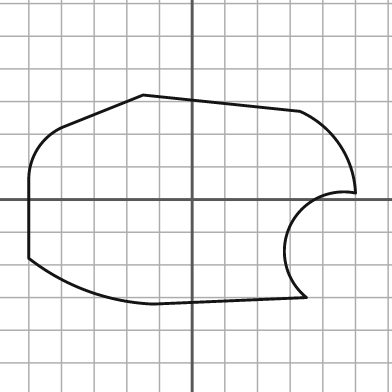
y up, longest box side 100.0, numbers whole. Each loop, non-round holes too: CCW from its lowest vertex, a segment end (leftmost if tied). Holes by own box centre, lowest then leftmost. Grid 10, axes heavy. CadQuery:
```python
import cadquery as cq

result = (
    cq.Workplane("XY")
    .moveTo(-12.0, -32.0)
    .lineTo(35.0, -30.0)
    .threePointArc((30.0, -8.0), (50.0, 2.0))
    .threePointArc((45.0, 17.0), (33.0, 27.0))
    .lineTo(-15.0, 32.0)
    .lineTo(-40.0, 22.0)
    .threePointArc((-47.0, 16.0), (-50.0, 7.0))
    .lineTo(-50.0, -18.0)
    .threePointArc((-32.0, -28.0), (-12.0, -32.0))
    .close()
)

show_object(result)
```